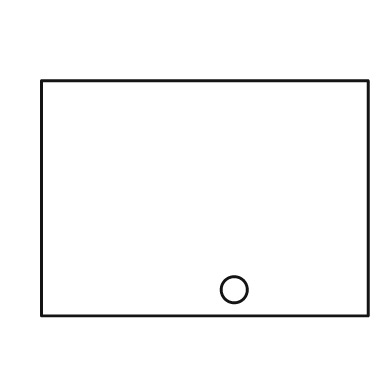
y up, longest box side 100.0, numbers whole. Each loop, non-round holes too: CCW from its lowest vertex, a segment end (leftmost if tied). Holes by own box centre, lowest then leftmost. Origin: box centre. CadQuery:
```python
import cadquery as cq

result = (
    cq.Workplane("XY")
    .moveTo(-50.0, -36.0)
    .lineTo(50.0, -36.0)
    .lineTo(50.0, 36.0)
    .lineTo(-50.0, 36.0)
    .close()
    .moveTo(9.0, -28.0)
    .circle(4.0)
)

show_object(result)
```